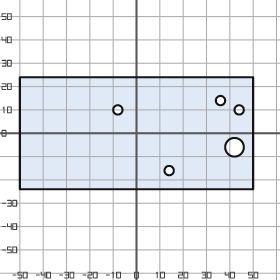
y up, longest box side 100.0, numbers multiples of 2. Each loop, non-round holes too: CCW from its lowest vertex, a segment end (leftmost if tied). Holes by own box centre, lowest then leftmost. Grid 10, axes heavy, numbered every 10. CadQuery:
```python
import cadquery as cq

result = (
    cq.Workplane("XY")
    .moveTo(-50.0, -24.0)
    .lineTo(50.0, -24.0)
    .lineTo(50.0, 24.0)
    .lineTo(-50.0, 24.0)
    .close()
    .moveTo(14.0, -16.0)
    .circle(2.0)
    .moveTo(42.0, -6.0)
    .circle(4.0)
    .moveTo(-8.0, 10.0)
    .circle(2.0)
    .moveTo(44.0, 10.0)
    .circle(2.0)
    .moveTo(36.0, 14.0)
    .circle(2.0)
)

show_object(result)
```